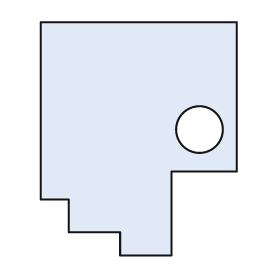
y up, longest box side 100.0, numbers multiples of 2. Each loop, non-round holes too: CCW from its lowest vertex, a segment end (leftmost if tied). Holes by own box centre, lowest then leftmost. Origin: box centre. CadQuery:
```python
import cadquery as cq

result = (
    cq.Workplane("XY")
    .moveTo(-8.0, -50.0)
    .lineTo(14.0, -50.0)
    .lineTo(14.0, -14.0)
    .lineTo(42.0, -14.0)
    .lineTo(42.0, 50.0)
    .lineTo(-42.0, 50.0)
    .lineTo(-42.0, -26.0)
    .lineTo(-30.0, -26.0)
    .lineTo(-30.0, -40.0)
    .lineTo(-8.0, -40.0)
    .close()
    .moveTo(26.0, 4.0)
    .circle(10.0)
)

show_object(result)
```